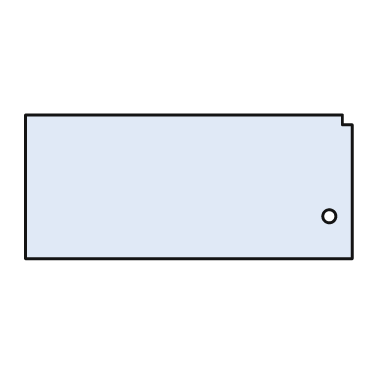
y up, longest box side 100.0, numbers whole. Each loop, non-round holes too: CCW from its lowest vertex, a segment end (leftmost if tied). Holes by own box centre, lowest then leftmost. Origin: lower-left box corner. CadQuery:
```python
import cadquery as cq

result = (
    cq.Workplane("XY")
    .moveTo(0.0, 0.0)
    .lineTo(100.0, 0.0)
    .lineTo(100.0, 41.0)
    .lineTo(97.0, 41.0)
    .lineTo(97.0, 44.0)
    .lineTo(0.0, 44.0)
    .close()
    .moveTo(93.0, 13.0)
    .circle(2.0)
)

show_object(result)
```